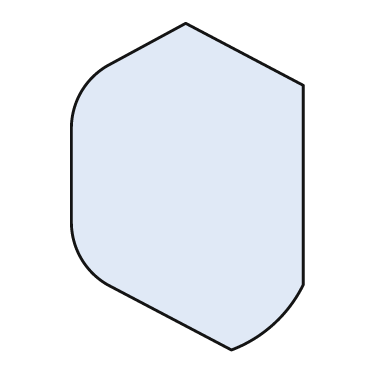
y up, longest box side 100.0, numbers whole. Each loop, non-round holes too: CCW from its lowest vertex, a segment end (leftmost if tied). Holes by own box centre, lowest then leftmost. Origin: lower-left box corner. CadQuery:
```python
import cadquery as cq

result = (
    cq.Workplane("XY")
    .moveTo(49.0, 0.0)
    .threePointArc((62.0, 8.0), (71.0, 20.0))
    .lineTo(71.0, 81.0)
    .lineTo(35.0, 100.0)
    .lineTo(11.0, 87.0)
    .threePointArc((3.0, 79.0), (0.0, 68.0))
    .lineTo(0.0, 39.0)
    .threePointArc((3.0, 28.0), (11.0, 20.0))
    .close()
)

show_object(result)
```